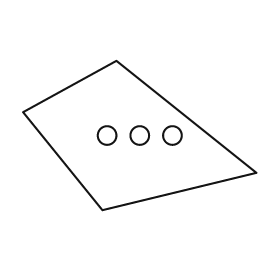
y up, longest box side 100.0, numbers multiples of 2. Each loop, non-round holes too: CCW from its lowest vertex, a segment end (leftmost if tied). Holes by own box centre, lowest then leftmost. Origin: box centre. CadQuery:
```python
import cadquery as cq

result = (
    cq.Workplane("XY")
    .moveTo(-16.0, -32.0)
    .lineTo(50.0, -16.0)
    .lineTo(-10.0, 32.0)
    .lineTo(-50.0, 10.0)
    .close()
    .moveTo(-14.0, 0.0)
    .circle(4.0)
    .moveTo(0.0, 0.0)
    .circle(4.0)
    .moveTo(14.0, 0.0)
    .circle(4.0)
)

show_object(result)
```